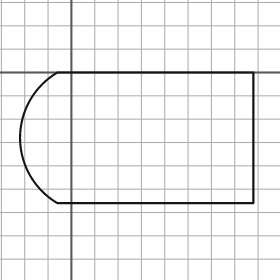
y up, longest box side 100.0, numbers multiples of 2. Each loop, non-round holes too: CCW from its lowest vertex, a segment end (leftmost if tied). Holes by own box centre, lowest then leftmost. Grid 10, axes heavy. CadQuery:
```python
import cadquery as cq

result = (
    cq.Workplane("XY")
    .moveTo(-6.0, -56.0)
    .lineTo(78.0, -56.0)
    .lineTo(78.0, 0.0)
    .lineTo(-6.0, 0.0)
    .threePointArc((-22.0, -28.0), (-6.0, -56.0))
    .close()
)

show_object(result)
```